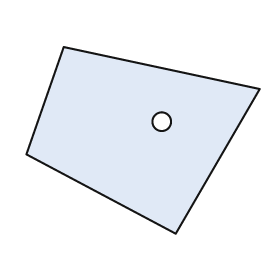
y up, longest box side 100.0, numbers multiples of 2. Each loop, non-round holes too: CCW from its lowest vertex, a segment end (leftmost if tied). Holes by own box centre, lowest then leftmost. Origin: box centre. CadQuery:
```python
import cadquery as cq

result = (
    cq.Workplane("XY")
    .moveTo(14.0, -40.0)
    .lineTo(50.0, 22.0)
    .lineTo(-34.0, 40.0)
    .lineTo(-50.0, -6.0)
    .close()
    .moveTo(8.0, 8.0)
    .circle(4.0)
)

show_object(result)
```